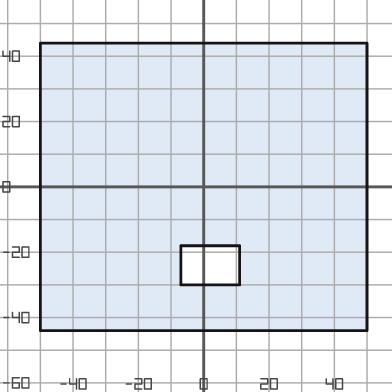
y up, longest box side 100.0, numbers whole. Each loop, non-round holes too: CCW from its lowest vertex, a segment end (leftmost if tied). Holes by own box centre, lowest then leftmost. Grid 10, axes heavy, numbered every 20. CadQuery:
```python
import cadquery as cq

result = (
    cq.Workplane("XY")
    .moveTo(-50.0, -44.0)
    .lineTo(50.0, -44.0)
    .lineTo(50.0, 44.0)
    .lineTo(-50.0, 44.0)
    .close()
    .moveTo(-7.0, -30.0)
    .lineTo(11.0, -30.0)
    .lineTo(11.0, -18.0)
    .lineTo(-7.0, -18.0)
    .close()
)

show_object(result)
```